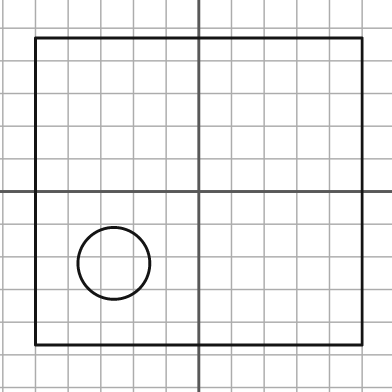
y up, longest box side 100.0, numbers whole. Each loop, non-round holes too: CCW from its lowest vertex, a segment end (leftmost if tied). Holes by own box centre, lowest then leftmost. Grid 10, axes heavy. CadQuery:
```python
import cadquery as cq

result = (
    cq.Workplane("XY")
    .moveTo(-50.0, -47.0)
    .lineTo(50.0, -47.0)
    .lineTo(50.0, 47.0)
    .lineTo(-50.0, 47.0)
    .close()
    .moveTo(-26.0, -22.0)
    .circle(11.0)
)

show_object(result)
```